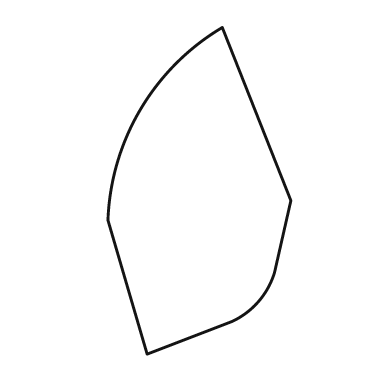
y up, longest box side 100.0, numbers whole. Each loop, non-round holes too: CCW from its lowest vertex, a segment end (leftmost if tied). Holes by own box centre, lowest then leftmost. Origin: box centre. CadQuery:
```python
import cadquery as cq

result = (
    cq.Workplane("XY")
    .moveTo(-16.0, -50.0)
    .lineTo(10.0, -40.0)
    .threePointArc((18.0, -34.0), (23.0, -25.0))
    .lineTo(28.0, -3.0)
    .lineTo(7.0, 50.0)
    .threePointArc((-18.0, 25.0), (-28.0, -9.0))
    .close()
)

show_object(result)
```